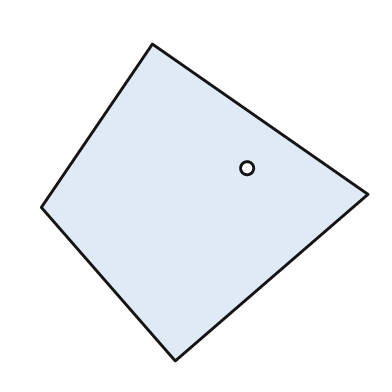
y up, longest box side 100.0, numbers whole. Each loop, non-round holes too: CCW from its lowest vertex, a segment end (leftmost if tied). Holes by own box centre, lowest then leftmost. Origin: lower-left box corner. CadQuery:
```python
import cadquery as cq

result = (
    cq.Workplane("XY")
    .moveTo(41.0, 0.0)
    .lineTo(100.0, 51.0)
    .lineTo(34.0, 97.0)
    .lineTo(0.0, 47.0)
    .close()
    .moveTo(63.0, 59.0)
    .circle(2.0)
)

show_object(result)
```